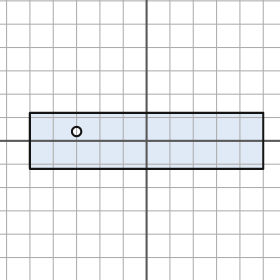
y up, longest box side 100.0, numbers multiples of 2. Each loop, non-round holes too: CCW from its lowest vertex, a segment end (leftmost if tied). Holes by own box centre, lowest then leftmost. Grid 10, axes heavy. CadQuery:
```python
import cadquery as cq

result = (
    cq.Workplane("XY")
    .moveTo(-50.0, -12.0)
    .lineTo(50.0, -12.0)
    .lineTo(50.0, 12.0)
    .lineTo(-50.0, 12.0)
    .close()
    .moveTo(-30.0, 4.0)
    .circle(2.0)
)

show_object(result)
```